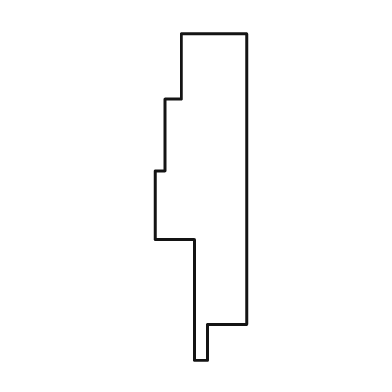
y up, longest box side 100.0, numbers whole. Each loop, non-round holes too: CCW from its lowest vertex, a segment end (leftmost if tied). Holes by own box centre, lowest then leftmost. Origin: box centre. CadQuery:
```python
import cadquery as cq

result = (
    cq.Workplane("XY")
    .moveTo(-2.0, -50.0)
    .lineTo(2.0, -50.0)
    .lineTo(2.0, -39.0)
    .lineTo(14.0, -39.0)
    .lineTo(14.0, 50.0)
    .lineTo(-6.0, 50.0)
    .lineTo(-6.0, 30.0)
    .lineTo(-11.0, 30.0)
    .lineTo(-11.0, 8.0)
    .lineTo(-14.0, 8.0)
    .lineTo(-14.0, -13.0)
    .lineTo(-2.0, -13.0)
    .close()
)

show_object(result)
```